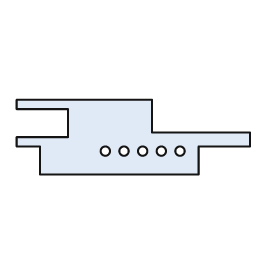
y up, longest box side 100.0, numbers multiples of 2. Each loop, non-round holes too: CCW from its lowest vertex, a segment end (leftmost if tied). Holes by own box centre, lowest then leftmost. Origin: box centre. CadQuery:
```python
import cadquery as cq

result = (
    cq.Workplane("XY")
    .moveTo(-40.0, -16.0)
    .lineTo(28.0, -16.0)
    .lineTo(28.0, -4.0)
    .lineTo(50.0, -4.0)
    .lineTo(50.0, 2.0)
    .lineTo(8.0, 2.0)
    .lineTo(8.0, 16.0)
    .lineTo(-50.0, 16.0)
    .lineTo(-50.0, 12.0)
    .lineTo(-28.0, 12.0)
    .lineTo(-28.0, 0.0)
    .lineTo(-50.0, 0.0)
    .lineTo(-50.0, -4.0)
    .lineTo(-40.0, -4.0)
    .close()
    .moveTo(-12.0, -6.0)
    .circle(2.0)
    .moveTo(-4.0, -6.0)
    .circle(2.0)
    .moveTo(4.0, -6.0)
    .circle(2.0)
    .moveTo(12.0, -6.0)
    .circle(2.0)
    .moveTo(20.0, -6.0)
    .circle(2.0)
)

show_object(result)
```